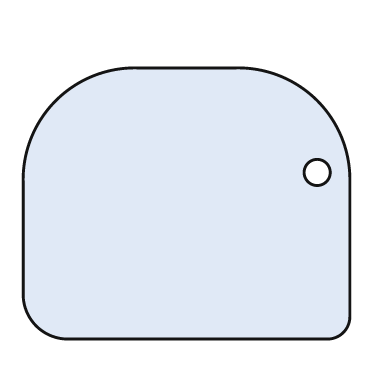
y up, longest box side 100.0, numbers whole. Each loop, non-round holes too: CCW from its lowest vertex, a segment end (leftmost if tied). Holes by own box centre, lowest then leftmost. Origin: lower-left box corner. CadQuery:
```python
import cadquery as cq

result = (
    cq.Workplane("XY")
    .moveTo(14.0, 0.0)
    .lineTo(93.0, 0.0)
    .threePointArc((98.0, 2.0), (100.0, 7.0))
    .lineTo(100.0, 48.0)
    .threePointArc((90.0, 73.0), (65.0, 83.0))
    .lineTo(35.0, 83.0)
    .threePointArc((10.0, 73.0), (0.0, 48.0))
    .lineTo(0.0, 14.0)
    .threePointArc((4.0, 4.0), (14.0, 0.0))
    .close()
    .moveTo(90.0, 51.0)
    .circle(4.0)
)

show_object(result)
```